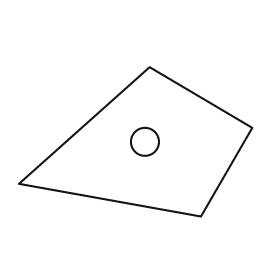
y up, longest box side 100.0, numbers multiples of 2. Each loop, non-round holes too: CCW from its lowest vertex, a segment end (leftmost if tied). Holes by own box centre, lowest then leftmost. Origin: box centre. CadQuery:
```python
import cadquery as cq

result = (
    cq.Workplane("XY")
    .moveTo(28.0, -32.0)
    .lineTo(50.0, 6.0)
    .lineTo(6.0, 32.0)
    .lineTo(-50.0, -18.0)
    .close()
    .moveTo(4.0, 0.0)
    .circle(6.0)
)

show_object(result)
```